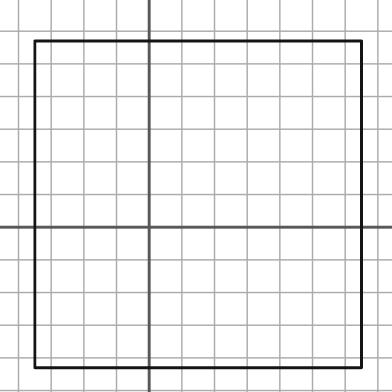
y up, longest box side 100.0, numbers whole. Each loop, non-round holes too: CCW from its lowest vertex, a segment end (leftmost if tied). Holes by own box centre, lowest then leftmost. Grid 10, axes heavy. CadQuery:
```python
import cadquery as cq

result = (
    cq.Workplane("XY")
    .moveTo(-35.0, -43.0)
    .lineTo(65.0, -43.0)
    .lineTo(65.0, 57.0)
    .lineTo(-35.0, 57.0)
    .close()
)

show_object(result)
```